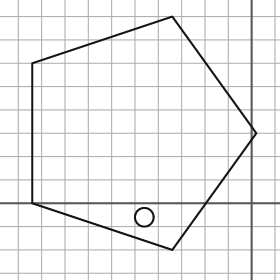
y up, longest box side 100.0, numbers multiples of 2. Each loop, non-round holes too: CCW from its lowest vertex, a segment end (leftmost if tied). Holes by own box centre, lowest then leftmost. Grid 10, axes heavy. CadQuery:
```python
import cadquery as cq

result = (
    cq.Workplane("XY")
    .moveTo(-34.0, -20.0)
    .lineTo(2.0, 30.0)
    .lineTo(-34.0, 80.0)
    .lineTo(-94.0, 60.0)
    .lineTo(-94.0, 0.0)
    .close()
    .moveTo(-46.0, -6.0)
    .circle(4.0)
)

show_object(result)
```